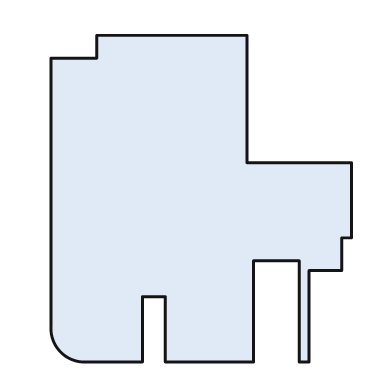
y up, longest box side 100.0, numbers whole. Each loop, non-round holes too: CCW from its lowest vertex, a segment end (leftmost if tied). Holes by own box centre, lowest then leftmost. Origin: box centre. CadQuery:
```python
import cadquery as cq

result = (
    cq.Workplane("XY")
    .moveTo(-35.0, -50.0)
    .lineTo(-18.0, -50.0)
    .lineTo(-18.0, -30.0)
    .lineTo(-11.0, -30.0)
    .lineTo(-11.0, -50.0)
    .lineTo(16.0, -50.0)
    .lineTo(16.0, -19.0)
    .lineTo(30.0, -19.0)
    .lineTo(30.0, -50.0)
    .lineTo(33.0, -50.0)
    .lineTo(33.0, -22.0)
    .lineTo(43.0, -22.0)
    .lineTo(43.0, -12.0)
    .lineTo(46.0, -12.0)
    .lineTo(46.0, 11.0)
    .lineTo(14.0, 11.0)
    .lineTo(14.0, 50.0)
    .lineTo(-32.0, 50.0)
    .lineTo(-32.0, 43.0)
    .lineTo(-46.0, 43.0)
    .lineTo(-46.0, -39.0)
    .threePointArc((-43.0, -47.0), (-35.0, -50.0))
    .close()
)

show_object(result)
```